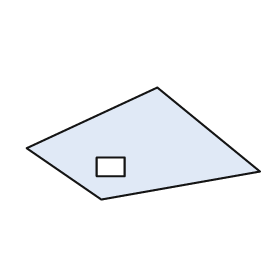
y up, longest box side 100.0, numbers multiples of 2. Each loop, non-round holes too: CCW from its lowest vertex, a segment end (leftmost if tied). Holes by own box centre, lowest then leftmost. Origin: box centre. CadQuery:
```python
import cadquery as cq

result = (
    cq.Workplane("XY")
    .moveTo(-18.0, -24.0)
    .lineTo(50.0, -12.0)
    .lineTo(6.0, 24.0)
    .lineTo(-50.0, -2.0)
    .close()
    .moveTo(-20.0, -14.0)
    .lineTo(-8.0, -14.0)
    .lineTo(-8.0, -6.0)
    .lineTo(-20.0, -6.0)
    .close()
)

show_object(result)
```